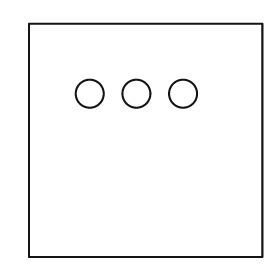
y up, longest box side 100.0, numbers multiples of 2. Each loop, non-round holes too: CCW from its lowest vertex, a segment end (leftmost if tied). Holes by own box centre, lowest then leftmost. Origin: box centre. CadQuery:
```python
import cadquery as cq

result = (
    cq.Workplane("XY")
    .moveTo(-50.0, -50.0)
    .lineTo(50.0, -50.0)
    .lineTo(50.0, 50.0)
    .lineTo(-50.0, 50.0)
    .close()
    .moveTo(-24.0, 20.0)
    .circle(6.0)
    .moveTo(-4.0, 20.0)
    .circle(6.0)
    .moveTo(16.0, 20.0)
    .circle(6.0)
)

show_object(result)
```